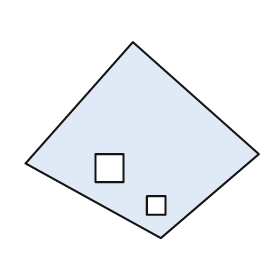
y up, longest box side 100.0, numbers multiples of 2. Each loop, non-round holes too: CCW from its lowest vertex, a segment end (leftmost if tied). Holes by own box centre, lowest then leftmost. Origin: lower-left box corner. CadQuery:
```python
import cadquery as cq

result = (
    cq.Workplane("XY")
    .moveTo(58.0, 0.0)
    .lineTo(100.0, 36.0)
    .lineTo(46.0, 84.0)
    .lineTo(0.0, 32.0)
    .close()
    .moveTo(52.0, 10.0)
    .lineTo(60.0, 10.0)
    .lineTo(60.0, 18.0)
    .lineTo(52.0, 18.0)
    .close()
    .moveTo(30.0, 24.0)
    .lineTo(42.0, 24.0)
    .lineTo(42.0, 36.0)
    .lineTo(30.0, 36.0)
    .close()
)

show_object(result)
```